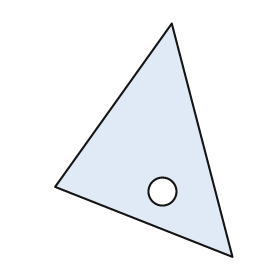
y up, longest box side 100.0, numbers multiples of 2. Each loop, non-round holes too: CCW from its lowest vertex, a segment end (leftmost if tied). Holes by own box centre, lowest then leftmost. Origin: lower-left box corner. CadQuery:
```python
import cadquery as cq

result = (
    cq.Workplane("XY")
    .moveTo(76.0, 0.0)
    .lineTo(50.0, 100.0)
    .lineTo(0.0, 30.0)
    .close()
    .moveTo(46.0, 28.0)
    .circle(6.0)
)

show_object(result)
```